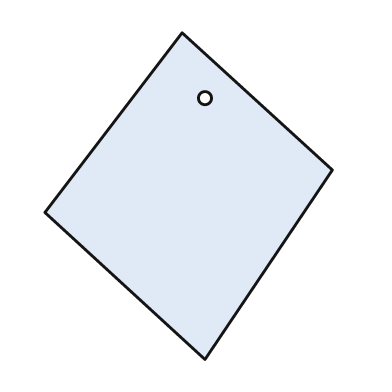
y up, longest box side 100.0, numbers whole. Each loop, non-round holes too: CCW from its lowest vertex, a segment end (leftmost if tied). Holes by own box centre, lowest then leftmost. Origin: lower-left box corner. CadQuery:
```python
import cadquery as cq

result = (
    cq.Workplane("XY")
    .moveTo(49.0, 0.0)
    .lineTo(88.0, 58.0)
    .lineTo(42.0, 100.0)
    .lineTo(0.0, 45.0)
    .close()
    .moveTo(49.0, 80.0)
    .circle(2.0)
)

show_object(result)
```